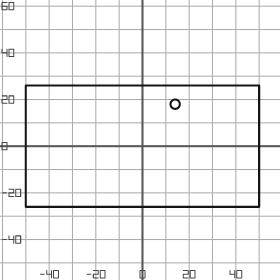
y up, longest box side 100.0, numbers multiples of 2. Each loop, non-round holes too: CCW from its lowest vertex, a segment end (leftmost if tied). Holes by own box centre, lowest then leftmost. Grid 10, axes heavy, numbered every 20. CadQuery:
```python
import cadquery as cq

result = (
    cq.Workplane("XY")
    .moveTo(-50.0, -26.0)
    .lineTo(50.0, -26.0)
    .lineTo(50.0, 26.0)
    .lineTo(-50.0, 26.0)
    .close()
    .moveTo(14.0, 18.0)
    .circle(2.0)
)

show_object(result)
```